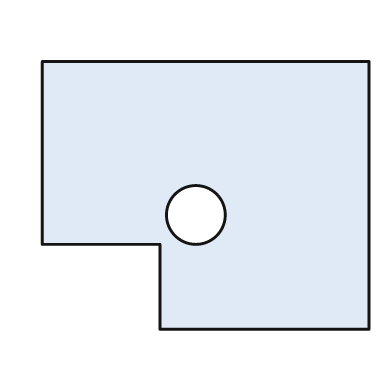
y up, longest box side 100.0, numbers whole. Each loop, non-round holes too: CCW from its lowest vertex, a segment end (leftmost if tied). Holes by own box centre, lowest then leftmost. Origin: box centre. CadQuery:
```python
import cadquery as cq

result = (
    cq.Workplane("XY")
    .moveTo(-14.0, -41.0)
    .lineTo(50.0, -41.0)
    .lineTo(50.0, 41.0)
    .lineTo(-50.0, 41.0)
    .lineTo(-50.0, -15.0)
    .lineTo(-14.0, -15.0)
    .close()
    .moveTo(-3.0, -6.0)
    .circle(9.0)
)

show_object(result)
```